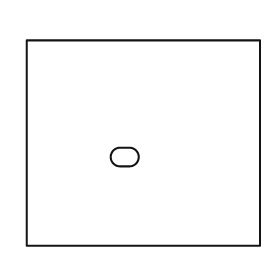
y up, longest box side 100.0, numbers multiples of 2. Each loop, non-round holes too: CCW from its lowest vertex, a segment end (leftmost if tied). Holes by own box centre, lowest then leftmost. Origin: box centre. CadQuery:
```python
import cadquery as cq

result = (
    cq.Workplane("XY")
    .moveTo(-50.0, -44.0)
    .lineTo(50.0, -44.0)
    .lineTo(50.0, 44.0)
    .lineTo(-50.0, 44.0)
    .close()
    .moveTo(-10.0, -10.0)
    .lineTo(-6.0, -10.0)
    .threePointArc((-2.0, -6.0), (-6.0, -2.0))
    .lineTo(-10.0, -2.0)
    .threePointArc((-14.0, -6.0), (-10.0, -10.0))
    .close()
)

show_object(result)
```